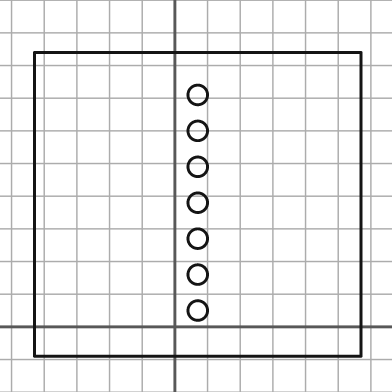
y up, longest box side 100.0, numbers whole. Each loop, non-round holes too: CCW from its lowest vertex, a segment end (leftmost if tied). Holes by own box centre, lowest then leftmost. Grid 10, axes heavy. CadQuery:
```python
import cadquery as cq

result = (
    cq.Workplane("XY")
    .moveTo(-43.0, -9.0)
    .lineTo(57.0, -9.0)
    .lineTo(57.0, 84.0)
    .lineTo(-43.0, 84.0)
    .close()
    .moveTo(7.0, 5.0)
    .circle(3.0)
    .moveTo(7.0, 16.0)
    .circle(3.0)
    .moveTo(7.0, 27.0)
    .circle(3.0)
    .moveTo(7.0, 38.0)
    .circle(3.0)
    .moveTo(7.0, 49.0)
    .circle(3.0)
    .moveTo(7.0, 60.0)
    .circle(3.0)
    .moveTo(7.0, 71.0)
    .circle(3.0)
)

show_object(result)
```